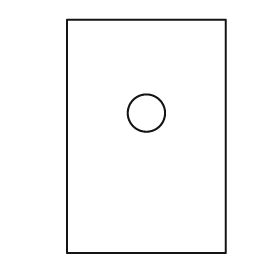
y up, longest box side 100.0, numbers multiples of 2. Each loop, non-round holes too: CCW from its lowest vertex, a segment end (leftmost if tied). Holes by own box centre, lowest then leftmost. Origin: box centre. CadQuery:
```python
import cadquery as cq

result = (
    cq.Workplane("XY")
    .moveTo(-34.0, -50.0)
    .lineTo(34.0, -50.0)
    .lineTo(34.0, 50.0)
    .lineTo(-34.0, 50.0)
    .close()
    .moveTo(0.0, 10.0)
    .circle(8.0)
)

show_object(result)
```